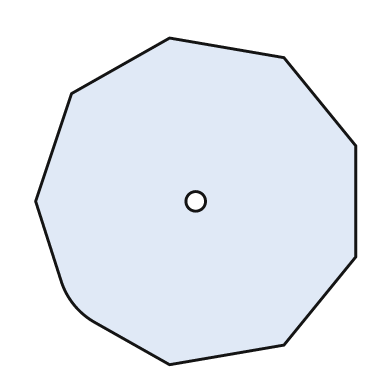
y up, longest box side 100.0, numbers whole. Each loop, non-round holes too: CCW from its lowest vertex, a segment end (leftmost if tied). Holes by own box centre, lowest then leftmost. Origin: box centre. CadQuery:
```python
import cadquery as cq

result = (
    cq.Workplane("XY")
    .moveTo(-8.0, -50.0)
    .lineTo(27.0, -44.0)
    .lineTo(49.0, -17.0)
    .lineTo(49.0, 17.0)
    .lineTo(27.0, 44.0)
    .lineTo(-8.0, 50.0)
    .lineTo(-38.0, 33.0)
    .lineTo(-49.0, 0.0)
    .lineTo(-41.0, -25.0)
    .threePointArc((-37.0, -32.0), (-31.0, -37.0))
    .close()
    .moveTo(0.0, 0.0)
    .circle(3.0)
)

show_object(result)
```